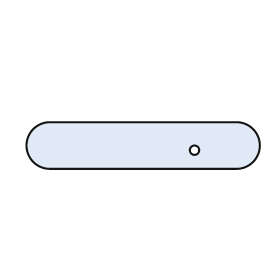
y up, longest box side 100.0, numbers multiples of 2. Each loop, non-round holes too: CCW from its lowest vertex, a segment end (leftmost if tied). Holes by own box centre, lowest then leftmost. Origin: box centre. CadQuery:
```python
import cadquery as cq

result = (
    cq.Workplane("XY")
    .moveTo(-40.0, -10.0)
    .lineTo(40.0, -10.0)
    .threePointArc((50.0, 0.0), (40.0, 10.0))
    .lineTo(-40.0, 10.0)
    .threePointArc((-50.0, 0.0), (-40.0, -10.0))
    .close()
    .moveTo(22.0, -2.0)
    .circle(2.0)
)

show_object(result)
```